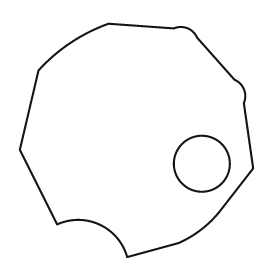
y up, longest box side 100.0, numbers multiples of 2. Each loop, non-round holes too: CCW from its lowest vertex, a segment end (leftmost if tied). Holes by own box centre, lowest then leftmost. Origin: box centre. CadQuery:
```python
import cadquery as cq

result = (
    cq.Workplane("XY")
    .moveTo(-4.0, -50.0)
    .lineTo(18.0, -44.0)
    .threePointArc((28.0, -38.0), (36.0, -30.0))
    .lineTo(50.0, -12.0)
    .lineTo(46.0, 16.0)
    .threePointArc((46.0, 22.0), (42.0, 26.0))
    .lineTo(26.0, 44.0)
    .threePointArc((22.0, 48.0), (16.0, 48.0))
    .lineTo(-12.0, 50.0)
    .threePointArc((-28.0, 42.0), (-42.0, 30.0))
    .lineTo(-50.0, -4.0)
    .lineTo(-34.0, -36.0)
    .threePointArc((-16.0, -36.0), (-4.0, -50.0))
    .close()
    .moveTo(28.0, -10.0)
    .circle(12.0)
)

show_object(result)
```